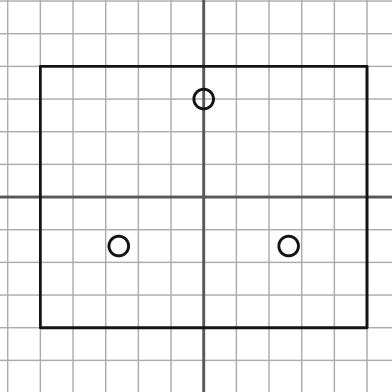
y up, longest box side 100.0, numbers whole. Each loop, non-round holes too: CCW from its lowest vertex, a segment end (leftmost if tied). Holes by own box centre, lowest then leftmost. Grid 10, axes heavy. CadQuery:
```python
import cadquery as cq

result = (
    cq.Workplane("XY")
    .moveTo(-50.0, -40.0)
    .lineTo(50.0, -40.0)
    .lineTo(50.0, 40.0)
    .lineTo(-50.0, 40.0)
    .close()
    .moveTo(-26.0, -15.0)
    .circle(3.0)
    .moveTo(26.0, -15.0)
    .circle(3.0)
    .moveTo(0.0, 30.0)
    .circle(3.0)
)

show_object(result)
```